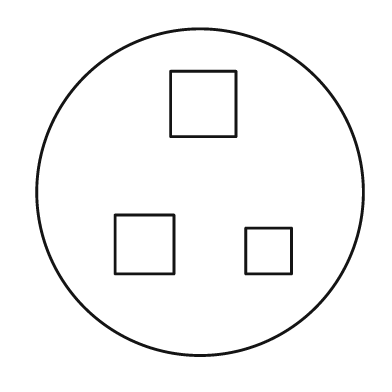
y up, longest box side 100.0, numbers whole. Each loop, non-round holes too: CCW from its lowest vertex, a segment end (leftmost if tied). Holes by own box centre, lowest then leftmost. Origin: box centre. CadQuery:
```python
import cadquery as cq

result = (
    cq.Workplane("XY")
    .moveTo(0.0, 0.0)
    .circle(50.0)
    .moveTo(14.0, -25.0)
    .lineTo(28.0, -25.0)
    .lineTo(28.0, -11.0)
    .lineTo(14.0, -11.0)
    .close()
    .moveTo(-26.0, -25.0)
    .lineTo(-8.0, -25.0)
    .lineTo(-8.0, -7.0)
    .lineTo(-26.0, -7.0)
    .close()
    .moveTo(-9.0, 17.0)
    .lineTo(11.0, 17.0)
    .lineTo(11.0, 37.0)
    .lineTo(-9.0, 37.0)
    .close()
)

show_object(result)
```